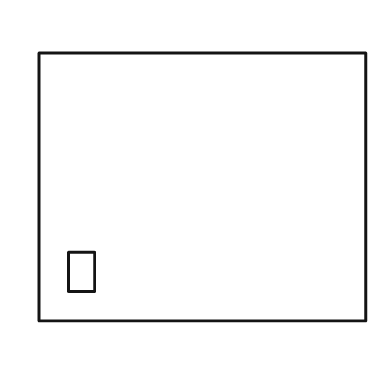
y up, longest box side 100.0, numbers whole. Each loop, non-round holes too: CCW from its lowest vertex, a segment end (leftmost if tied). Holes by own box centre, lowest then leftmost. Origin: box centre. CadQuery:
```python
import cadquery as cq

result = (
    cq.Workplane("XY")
    .moveTo(-50.0, -41.0)
    .lineTo(50.0, -41.0)
    .lineTo(50.0, 41.0)
    .lineTo(-50.0, 41.0)
    .close()
    .moveTo(-41.0, -32.0)
    .lineTo(-33.0, -32.0)
    .lineTo(-33.0, -20.0)
    .lineTo(-41.0, -20.0)
    .close()
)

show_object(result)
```